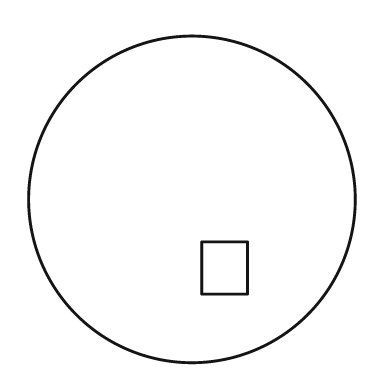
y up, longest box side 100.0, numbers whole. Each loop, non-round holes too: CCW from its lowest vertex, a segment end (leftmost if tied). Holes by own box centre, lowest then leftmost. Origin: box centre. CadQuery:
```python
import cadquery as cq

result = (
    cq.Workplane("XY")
    .moveTo(0.0, 0.0)
    .circle(50.0)
    .moveTo(3.0, -29.0)
    .lineTo(17.0, -29.0)
    .lineTo(17.0, -13.0)
    .lineTo(3.0, -13.0)
    .close()
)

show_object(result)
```